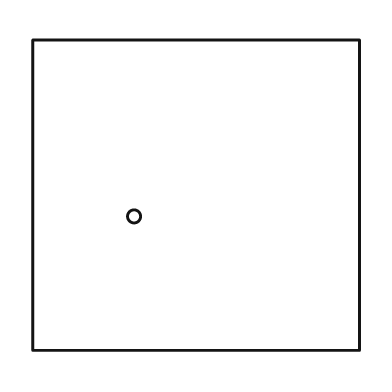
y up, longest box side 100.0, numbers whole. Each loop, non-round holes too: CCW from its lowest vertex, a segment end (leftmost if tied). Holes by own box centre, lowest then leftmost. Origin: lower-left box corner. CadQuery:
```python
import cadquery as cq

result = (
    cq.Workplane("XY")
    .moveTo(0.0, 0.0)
    .lineTo(100.0, 0.0)
    .lineTo(100.0, 95.0)
    .lineTo(0.0, 95.0)
    .close()
    .moveTo(31.0, 41.0)
    .circle(2.0)
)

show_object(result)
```